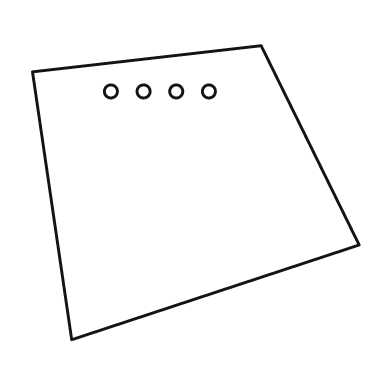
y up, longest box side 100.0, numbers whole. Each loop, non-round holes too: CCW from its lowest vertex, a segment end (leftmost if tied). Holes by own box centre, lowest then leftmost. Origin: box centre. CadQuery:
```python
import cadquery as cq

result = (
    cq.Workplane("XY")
    .moveTo(-38.0, -45.0)
    .lineTo(50.0, -16.0)
    .lineTo(20.0, 45.0)
    .lineTo(-50.0, 37.0)
    .close()
    .moveTo(-26.0, 31.0)
    .circle(2.0)
    .moveTo(-16.0, 31.0)
    .circle(2.0)
    .moveTo(-6.0, 31.0)
    .circle(2.0)
    .moveTo(4.0, 31.0)
    .circle(2.0)
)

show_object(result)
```